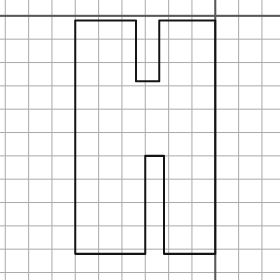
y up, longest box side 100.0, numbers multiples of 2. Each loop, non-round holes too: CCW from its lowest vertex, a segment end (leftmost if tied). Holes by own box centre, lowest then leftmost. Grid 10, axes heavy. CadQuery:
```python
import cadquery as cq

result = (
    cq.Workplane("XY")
    .moveTo(-60.0, -102.0)
    .lineTo(-30.0, -102.0)
    .lineTo(-30.0, -60.0)
    .lineTo(-22.0, -60.0)
    .lineTo(-22.0, -102.0)
    .lineTo(0.0, -102.0)
    .lineTo(0.0, -2.0)
    .lineTo(-24.0, -2.0)
    .lineTo(-24.0, -28.0)
    .lineTo(-34.0, -28.0)
    .lineTo(-34.0, -2.0)
    .lineTo(-60.0, -2.0)
    .close()
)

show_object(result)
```